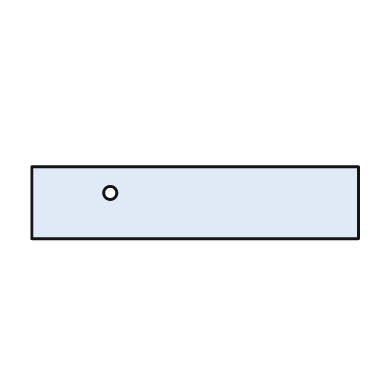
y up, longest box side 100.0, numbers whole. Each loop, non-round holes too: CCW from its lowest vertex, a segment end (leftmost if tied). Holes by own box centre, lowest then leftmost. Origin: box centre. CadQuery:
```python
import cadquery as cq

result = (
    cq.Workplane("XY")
    .moveTo(-50.0, -11.0)
    .lineTo(50.0, -11.0)
    .lineTo(50.0, 11.0)
    .lineTo(-50.0, 11.0)
    .close()
    .moveTo(-26.0, 3.0)
    .circle(2.0)
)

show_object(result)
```